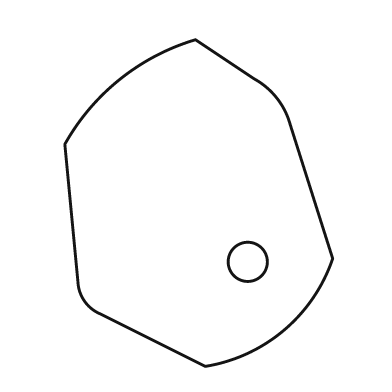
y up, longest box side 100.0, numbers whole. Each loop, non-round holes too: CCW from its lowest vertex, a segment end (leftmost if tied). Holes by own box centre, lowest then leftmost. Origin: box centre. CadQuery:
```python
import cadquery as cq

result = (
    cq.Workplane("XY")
    .moveTo(2.0, -50.0)
    .threePointArc((26.0, -39.0), (41.0, -17.0))
    .lineTo(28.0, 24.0)
    .threePointArc((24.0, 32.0), (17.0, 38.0))
    .lineTo(-1.0, 50.0)
    .threePointArc((-24.0, 38.0), (-41.0, 18.0))
    .lineTo(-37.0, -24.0)
    .threePointArc((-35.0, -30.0), (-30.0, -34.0))
    .close()
    .moveTo(15.0, -18.0)
    .circle(6.0)
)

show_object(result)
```